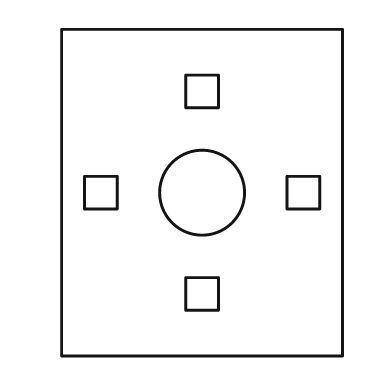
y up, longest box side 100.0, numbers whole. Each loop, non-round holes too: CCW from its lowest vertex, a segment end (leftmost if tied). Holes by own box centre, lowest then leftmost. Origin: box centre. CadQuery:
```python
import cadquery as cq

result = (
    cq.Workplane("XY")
    .moveTo(-43.0, -50.0)
    .lineTo(43.0, -50.0)
    .lineTo(43.0, 50.0)
    .lineTo(-43.0, 50.0)
    .close()
    .moveTo(-5.0, -36.0)
    .lineTo(5.0, -36.0)
    .lineTo(5.0, -26.0)
    .lineTo(-5.0, -26.0)
    .close()
    .moveTo(-36.0, -5.0)
    .lineTo(-26.0, -5.0)
    .lineTo(-26.0, 5.0)
    .lineTo(-36.0, 5.0)
    .close()
    .moveTo(0.0, 0.0)
    .circle(13.0)
    .moveTo(26.0, -5.0)
    .lineTo(36.0, -5.0)
    .lineTo(36.0, 5.0)
    .lineTo(26.0, 5.0)
    .close()
    .moveTo(-5.0, 26.0)
    .lineTo(5.0, 26.0)
    .lineTo(5.0, 36.0)
    .lineTo(-5.0, 36.0)
    .close()
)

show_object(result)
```